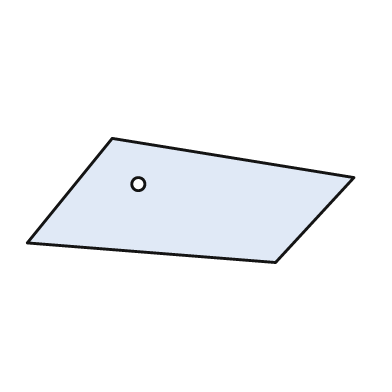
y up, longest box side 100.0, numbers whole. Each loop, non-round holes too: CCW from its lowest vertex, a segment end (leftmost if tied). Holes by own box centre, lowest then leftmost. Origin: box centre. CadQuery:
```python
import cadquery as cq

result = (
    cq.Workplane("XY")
    .moveTo(26.0, -19.0)
    .lineTo(50.0, 7.0)
    .lineTo(-24.0, 19.0)
    .lineTo(-50.0, -13.0)
    .close()
    .moveTo(-16.0, 5.0)
    .circle(2.0)
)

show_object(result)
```